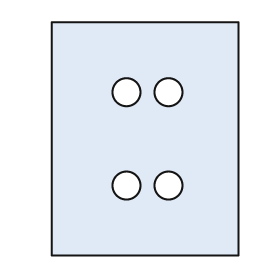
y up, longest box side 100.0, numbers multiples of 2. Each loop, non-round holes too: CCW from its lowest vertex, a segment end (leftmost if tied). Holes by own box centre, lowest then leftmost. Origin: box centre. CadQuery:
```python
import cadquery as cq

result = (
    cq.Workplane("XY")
    .moveTo(-40.0, -50.0)
    .lineTo(40.0, -50.0)
    .lineTo(40.0, 50.0)
    .lineTo(-40.0, 50.0)
    .close()
    .moveTo(-8.0, -20.0)
    .circle(6.0)
    .moveTo(10.0, -20.0)
    .circle(6.0)
    .moveTo(-8.0, 20.0)
    .circle(6.0)
    .moveTo(10.0, 20.0)
    .circle(6.0)
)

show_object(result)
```